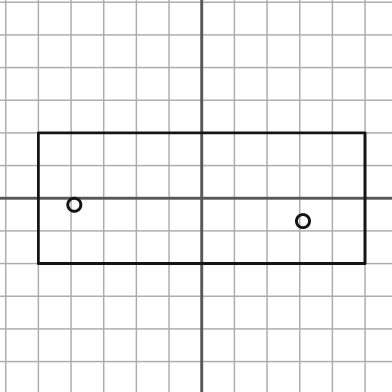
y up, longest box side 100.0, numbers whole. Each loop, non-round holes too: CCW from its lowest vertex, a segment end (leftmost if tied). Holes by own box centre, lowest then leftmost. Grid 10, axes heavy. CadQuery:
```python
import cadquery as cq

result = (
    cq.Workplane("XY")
    .moveTo(-50.0, -20.0)
    .lineTo(50.0, -20.0)
    .lineTo(50.0, 20.0)
    .lineTo(-50.0, 20.0)
    .close()
    .moveTo(31.0, -7.0)
    .circle(2.0)
    .moveTo(-39.0, -2.0)
    .circle(2.0)
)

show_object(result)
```